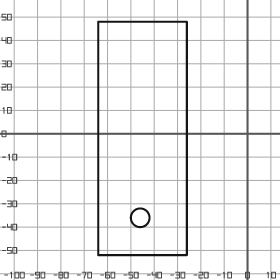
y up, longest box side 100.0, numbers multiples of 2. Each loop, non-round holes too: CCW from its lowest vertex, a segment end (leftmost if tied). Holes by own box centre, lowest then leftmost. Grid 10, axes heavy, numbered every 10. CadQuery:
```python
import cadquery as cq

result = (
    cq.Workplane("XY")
    .moveTo(-64.0, -52.0)
    .lineTo(-26.0, -52.0)
    .lineTo(-26.0, 48.0)
    .lineTo(-64.0, 48.0)
    .close()
    .moveTo(-46.0, -36.0)
    .circle(4.0)
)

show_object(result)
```